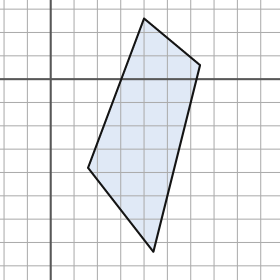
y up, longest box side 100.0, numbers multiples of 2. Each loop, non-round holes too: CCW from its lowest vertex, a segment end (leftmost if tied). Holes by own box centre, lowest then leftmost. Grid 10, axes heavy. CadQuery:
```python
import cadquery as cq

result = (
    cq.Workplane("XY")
    .moveTo(44.0, -74.0)
    .lineTo(64.0, 6.0)
    .lineTo(40.0, 26.0)
    .lineTo(16.0, -38.0)
    .close()
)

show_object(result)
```